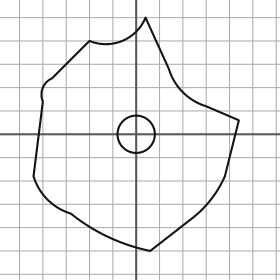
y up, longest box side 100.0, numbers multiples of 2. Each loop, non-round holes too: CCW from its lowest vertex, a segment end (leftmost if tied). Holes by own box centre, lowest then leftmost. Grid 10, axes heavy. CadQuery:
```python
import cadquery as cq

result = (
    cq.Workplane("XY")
    .moveTo(6.0, -50.0)
    .lineTo(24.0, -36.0)
    .threePointArc((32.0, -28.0), (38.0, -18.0))
    .lineTo(44.0, 6.0)
    .lineTo(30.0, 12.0)
    .threePointArc((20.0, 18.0), (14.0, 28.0))
    .lineTo(4.0, 50.0)
    .threePointArc((-6.0, 40.0), (-20.0, 40.0))
    .lineTo(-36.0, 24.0)
    .threePointArc((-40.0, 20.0), (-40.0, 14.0))
    .lineTo(-44.0, -18.0)
    .threePointArc((-38.0, -28.0), (-28.0, -34.0))
    .threePointArc((-12.0, -44.0), (6.0, -50.0))
    .close()
    .moveTo(0.0, 0.0)
    .circle(8.0)
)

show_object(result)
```